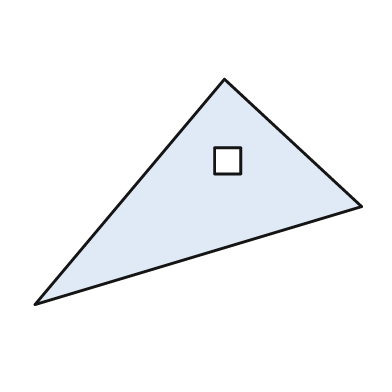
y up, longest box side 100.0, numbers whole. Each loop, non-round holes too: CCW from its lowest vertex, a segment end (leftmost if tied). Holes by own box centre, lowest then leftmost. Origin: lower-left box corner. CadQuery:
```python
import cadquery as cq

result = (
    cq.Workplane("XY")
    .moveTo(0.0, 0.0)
    .lineTo(100.0, 30.0)
    .lineTo(58.0, 69.0)
    .close()
    .moveTo(55.0, 40.0)
    .lineTo(63.0, 40.0)
    .lineTo(63.0, 48.0)
    .lineTo(55.0, 48.0)
    .close()
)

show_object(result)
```